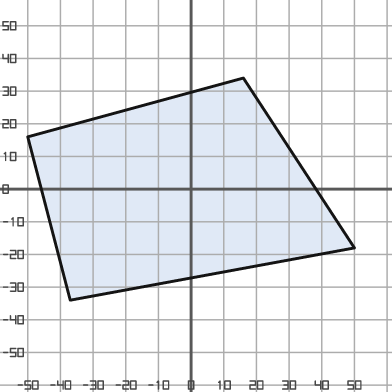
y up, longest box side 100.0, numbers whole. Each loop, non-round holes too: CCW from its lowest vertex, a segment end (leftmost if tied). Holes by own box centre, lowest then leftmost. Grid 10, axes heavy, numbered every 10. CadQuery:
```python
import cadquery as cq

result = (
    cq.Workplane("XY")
    .moveTo(-37.0, -34.0)
    .lineTo(50.0, -18.0)
    .lineTo(16.0, 34.0)
    .lineTo(-50.0, 16.0)
    .close()
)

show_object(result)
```